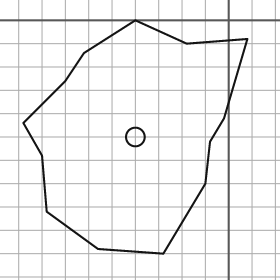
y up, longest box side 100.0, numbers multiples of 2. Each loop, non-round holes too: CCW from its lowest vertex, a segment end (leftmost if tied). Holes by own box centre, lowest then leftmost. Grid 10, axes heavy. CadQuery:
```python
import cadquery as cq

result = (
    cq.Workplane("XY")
    .moveTo(-28.0, -100.0)
    .lineTo(-10.0, -70.0)
    .lineTo(-8.0, -52.0)
    .lineTo(-2.0, -42.0)
    .lineTo(8.0, -8.0)
    .lineTo(-18.0, -10.0)
    .lineTo(-40.0, 0.0)
    .lineTo(-62.0, -14.0)
    .lineTo(-70.0, -26.0)
    .lineTo(-88.0, -44.0)
    .lineTo(-80.0, -58.0)
    .lineTo(-78.0, -82.0)
    .lineTo(-56.0, -98.0)
    .close()
    .moveTo(-40.0, -50.0)
    .circle(4.0)
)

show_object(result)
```